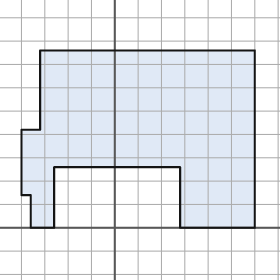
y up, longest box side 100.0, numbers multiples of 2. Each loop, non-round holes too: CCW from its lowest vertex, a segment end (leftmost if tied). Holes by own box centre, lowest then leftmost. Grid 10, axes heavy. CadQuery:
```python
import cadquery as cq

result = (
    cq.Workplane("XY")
    .moveTo(-36.0, 0.0)
    .lineTo(-26.0, 0.0)
    .lineTo(-26.0, 26.0)
    .lineTo(28.0, 26.0)
    .lineTo(28.0, 0.0)
    .lineTo(60.0, 0.0)
    .lineTo(60.0, 76.0)
    .lineTo(-32.0, 76.0)
    .lineTo(-32.0, 42.0)
    .lineTo(-40.0, 42.0)
    .lineTo(-40.0, 14.0)
    .lineTo(-36.0, 14.0)
    .close()
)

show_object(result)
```